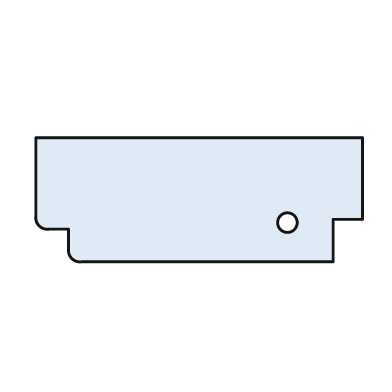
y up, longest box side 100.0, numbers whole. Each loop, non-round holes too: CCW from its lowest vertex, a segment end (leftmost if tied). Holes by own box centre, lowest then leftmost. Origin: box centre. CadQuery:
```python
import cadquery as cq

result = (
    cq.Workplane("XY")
    .moveTo(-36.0, -19.0)
    .lineTo(41.0, -19.0)
    .lineTo(41.0, -6.0)
    .lineTo(50.0, -6.0)
    .lineTo(50.0, 19.0)
    .lineTo(-50.0, 19.0)
    .lineTo(-50.0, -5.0)
    .threePointArc((-49.0, -8.0), (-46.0, -9.0))
    .lineTo(-40.0, -9.0)
    .lineTo(-40.0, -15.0)
    .threePointArc((-39.0, -18.0), (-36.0, -19.0))
    .close()
    .moveTo(27.0, -7.0)
    .circle(3.0)
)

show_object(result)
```